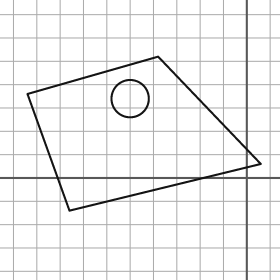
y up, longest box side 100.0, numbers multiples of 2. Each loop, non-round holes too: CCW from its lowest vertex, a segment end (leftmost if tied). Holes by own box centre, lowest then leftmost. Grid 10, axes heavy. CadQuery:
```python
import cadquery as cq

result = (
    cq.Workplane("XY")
    .moveTo(-76.0, -14.0)
    .lineTo(6.0, 6.0)
    .lineTo(-38.0, 52.0)
    .lineTo(-94.0, 36.0)
    .close()
    .moveTo(-50.0, 34.0)
    .circle(8.0)
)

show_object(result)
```